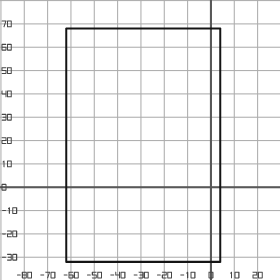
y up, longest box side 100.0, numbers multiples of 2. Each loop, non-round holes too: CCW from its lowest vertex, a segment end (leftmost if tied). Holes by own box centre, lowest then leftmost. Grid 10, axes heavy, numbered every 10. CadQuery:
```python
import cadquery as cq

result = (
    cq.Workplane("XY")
    .moveTo(-62.0, -32.0)
    .lineTo(4.0, -32.0)
    .lineTo(4.0, 68.0)
    .lineTo(-62.0, 68.0)
    .close()
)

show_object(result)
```